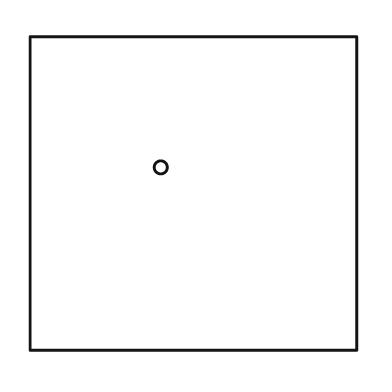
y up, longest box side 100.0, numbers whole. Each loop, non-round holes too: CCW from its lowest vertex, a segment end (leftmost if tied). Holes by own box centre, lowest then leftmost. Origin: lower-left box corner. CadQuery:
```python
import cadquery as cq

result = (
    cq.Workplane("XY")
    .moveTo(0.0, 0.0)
    .lineTo(100.0, 0.0)
    .lineTo(100.0, 96.0)
    .lineTo(0.0, 96.0)
    .close()
    .moveTo(40.0, 56.0)
    .circle(2.0)
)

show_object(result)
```